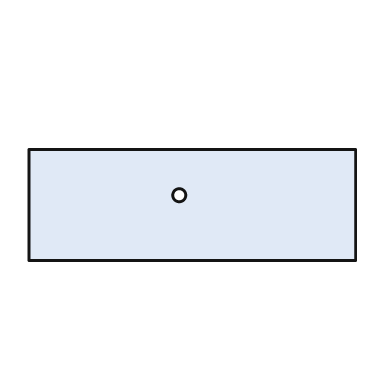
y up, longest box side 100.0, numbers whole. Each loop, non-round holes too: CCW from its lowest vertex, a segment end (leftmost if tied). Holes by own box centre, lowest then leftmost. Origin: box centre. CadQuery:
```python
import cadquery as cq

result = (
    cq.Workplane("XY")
    .moveTo(-50.0, -17.0)
    .lineTo(50.0, -17.0)
    .lineTo(50.0, 17.0)
    .lineTo(-50.0, 17.0)
    .close()
    .moveTo(-4.0, 3.0)
    .circle(2.0)
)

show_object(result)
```